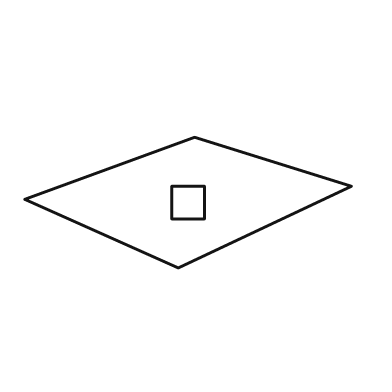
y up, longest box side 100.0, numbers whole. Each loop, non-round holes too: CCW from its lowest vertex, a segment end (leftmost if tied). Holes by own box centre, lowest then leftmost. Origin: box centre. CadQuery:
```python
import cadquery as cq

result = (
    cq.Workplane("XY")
    .moveTo(-3.0, -20.0)
    .lineTo(50.0, 5.0)
    .lineTo(2.0, 20.0)
    .lineTo(-50.0, 1.0)
    .close()
    .moveTo(-5.0, -5.0)
    .lineTo(5.0, -5.0)
    .lineTo(5.0, 5.0)
    .lineTo(-5.0, 5.0)
    .close()
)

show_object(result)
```